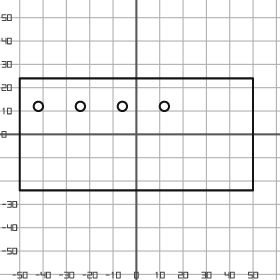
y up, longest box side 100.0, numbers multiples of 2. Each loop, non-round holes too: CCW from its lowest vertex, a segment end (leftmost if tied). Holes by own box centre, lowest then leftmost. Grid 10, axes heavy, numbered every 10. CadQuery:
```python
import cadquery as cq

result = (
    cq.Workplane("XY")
    .moveTo(-50.0, -24.0)
    .lineTo(50.0, -24.0)
    .lineTo(50.0, 24.0)
    .lineTo(-50.0, 24.0)
    .close()
    .moveTo(-42.0, 12.0)
    .circle(2.0)
    .moveTo(-24.0, 12.0)
    .circle(2.0)
    .moveTo(-6.0, 12.0)
    .circle(2.0)
    .moveTo(12.0, 12.0)
    .circle(2.0)
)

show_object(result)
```